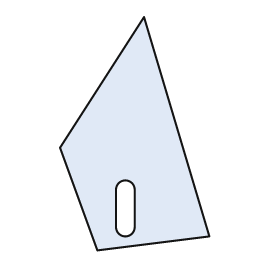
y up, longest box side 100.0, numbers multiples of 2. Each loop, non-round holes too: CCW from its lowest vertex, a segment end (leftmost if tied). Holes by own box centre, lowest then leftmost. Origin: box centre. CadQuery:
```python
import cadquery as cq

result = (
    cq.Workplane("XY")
    .moveTo(-16.0, -50.0)
    .lineTo(32.0, -44.0)
    .lineTo(4.0, 50.0)
    .lineTo(-32.0, -6.0)
    .close()
    .moveTo(-8.0, -40.0)
    .threePointArc((-4.0, -44.0), (0.0, -40.0))
    .lineTo(0.0, -24.0)
    .threePointArc((-4.0, -20.0), (-8.0, -24.0))
    .close()
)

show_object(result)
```